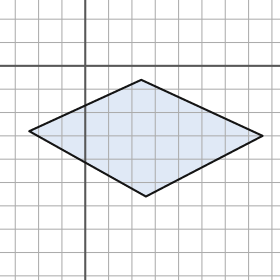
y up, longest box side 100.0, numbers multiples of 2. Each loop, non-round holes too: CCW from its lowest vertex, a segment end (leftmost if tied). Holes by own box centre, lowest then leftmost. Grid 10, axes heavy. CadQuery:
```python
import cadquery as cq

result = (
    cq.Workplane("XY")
    .moveTo(26.0, -56.0)
    .lineTo(76.0, -30.0)
    .lineTo(24.0, -6.0)
    .lineTo(-24.0, -28.0)
    .close()
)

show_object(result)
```